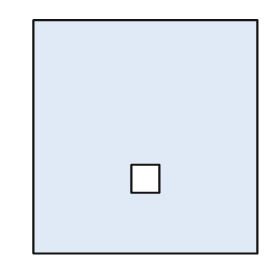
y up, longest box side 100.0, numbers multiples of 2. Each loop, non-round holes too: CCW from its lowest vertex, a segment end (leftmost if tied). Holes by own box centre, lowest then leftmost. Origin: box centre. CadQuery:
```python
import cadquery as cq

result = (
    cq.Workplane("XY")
    .moveTo(-48.0, -50.0)
    .lineTo(48.0, -50.0)
    .lineTo(48.0, 50.0)
    .lineTo(-48.0, 50.0)
    .close()
    .moveTo(-6.0, -24.0)
    .lineTo(6.0, -24.0)
    .lineTo(6.0, -12.0)
    .lineTo(-6.0, -12.0)
    .close()
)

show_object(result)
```